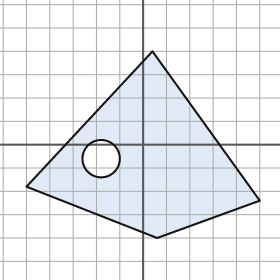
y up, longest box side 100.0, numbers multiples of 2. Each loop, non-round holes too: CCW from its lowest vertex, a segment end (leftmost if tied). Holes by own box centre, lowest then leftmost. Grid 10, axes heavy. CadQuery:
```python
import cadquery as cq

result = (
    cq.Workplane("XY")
    .moveTo(6.0, -40.0)
    .lineTo(50.0, -24.0)
    .lineTo(4.0, 40.0)
    .lineTo(-50.0, -18.0)
    .close()
    .moveTo(-18.0, -6.0)
    .circle(8.0)
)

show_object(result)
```